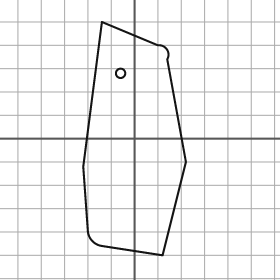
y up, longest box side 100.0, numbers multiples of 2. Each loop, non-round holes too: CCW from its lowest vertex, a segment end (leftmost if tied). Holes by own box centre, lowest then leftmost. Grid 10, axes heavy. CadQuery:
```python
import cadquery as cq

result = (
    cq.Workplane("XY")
    .moveTo(12.0, -50.0)
    .lineTo(22.0, -10.0)
    .lineTo(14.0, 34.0)
    .threePointArc((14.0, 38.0), (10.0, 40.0))
    .lineTo(-14.0, 50.0)
    .lineTo(-22.0, -12.0)
    .lineTo(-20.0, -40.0)
    .threePointArc((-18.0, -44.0), (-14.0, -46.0))
    .close()
    .moveTo(-6.0, 28.0)
    .circle(2.0)
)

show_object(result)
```